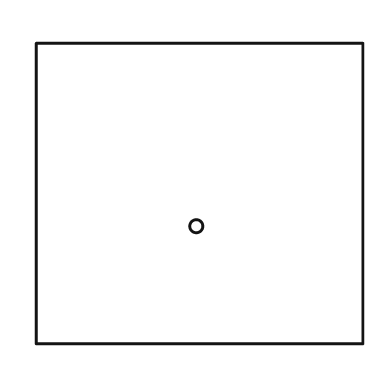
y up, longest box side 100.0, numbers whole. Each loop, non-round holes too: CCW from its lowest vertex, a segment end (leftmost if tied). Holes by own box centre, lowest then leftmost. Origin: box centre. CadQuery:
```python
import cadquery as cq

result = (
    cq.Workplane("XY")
    .moveTo(-50.0, -46.0)
    .lineTo(50.0, -46.0)
    .lineTo(50.0, 46.0)
    .lineTo(-50.0, 46.0)
    .close()
    .moveTo(-1.0, -10.0)
    .circle(2.0)
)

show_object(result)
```